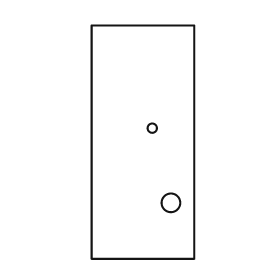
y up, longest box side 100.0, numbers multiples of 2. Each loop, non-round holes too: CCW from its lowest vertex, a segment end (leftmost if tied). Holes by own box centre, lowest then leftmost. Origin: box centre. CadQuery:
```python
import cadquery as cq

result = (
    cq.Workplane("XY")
    .moveTo(-22.0, -50.0)
    .lineTo(22.0, -50.0)
    .lineTo(22.0, 50.0)
    .lineTo(-22.0, 50.0)
    .close()
    .moveTo(12.0, -26.0)
    .circle(4.0)
    .moveTo(4.0, 6.0)
    .circle(2.0)
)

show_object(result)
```